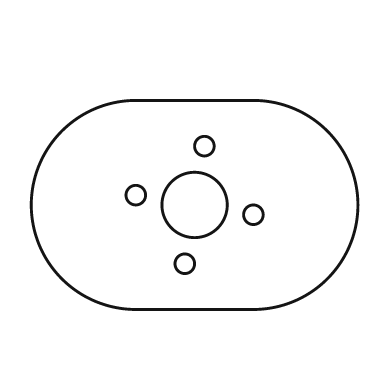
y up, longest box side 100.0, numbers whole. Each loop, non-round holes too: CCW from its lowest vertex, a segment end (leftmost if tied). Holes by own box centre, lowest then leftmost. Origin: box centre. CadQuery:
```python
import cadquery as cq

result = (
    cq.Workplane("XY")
    .moveTo(-18.0, -32.0)
    .lineTo(18.0, -32.0)
    .threePointArc((50.0, 0.0), (18.0, 32.0))
    .lineTo(-18.0, 32.0)
    .threePointArc((-50.0, 0.0), (-18.0, -32.0))
    .close()
    .moveTo(-3.0, -18.0)
    .circle(3.0)
    .moveTo(18.0, -3.0)
    .circle(3.0)
    .moveTo(0.0, 0.0)
    .circle(10.0)
    .moveTo(-18.0, 3.0)
    .circle(3.0)
    .moveTo(3.0, 18.0)
    .circle(3.0)
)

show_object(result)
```